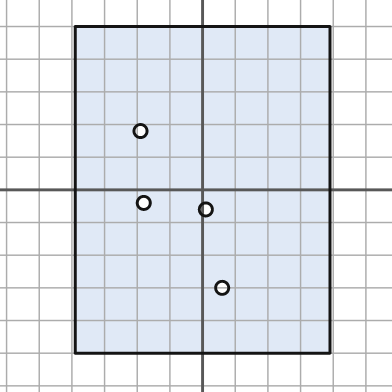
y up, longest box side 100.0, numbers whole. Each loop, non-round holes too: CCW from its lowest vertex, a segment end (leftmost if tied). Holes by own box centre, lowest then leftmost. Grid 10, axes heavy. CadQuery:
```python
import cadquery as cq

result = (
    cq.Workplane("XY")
    .moveTo(-39.0, -50.0)
    .lineTo(39.0, -50.0)
    .lineTo(39.0, 50.0)
    .lineTo(-39.0, 50.0)
    .close()
    .moveTo(6.0, -30.0)
    .circle(2.0)
    .moveTo(1.0, -6.0)
    .circle(2.0)
    .moveTo(-18.0, -4.0)
    .circle(2.0)
    .moveTo(-19.0, 18.0)
    .circle(2.0)
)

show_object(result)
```